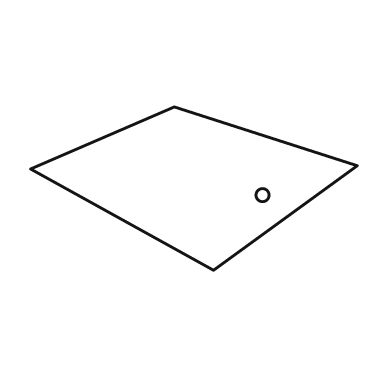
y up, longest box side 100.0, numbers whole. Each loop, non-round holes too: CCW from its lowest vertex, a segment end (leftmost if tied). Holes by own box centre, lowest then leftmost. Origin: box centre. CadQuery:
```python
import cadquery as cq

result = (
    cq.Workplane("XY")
    .moveTo(6.0, -25.0)
    .lineTo(50.0, 7.0)
    .lineTo(-6.0, 25.0)
    .lineTo(-50.0, 6.0)
    .close()
    .moveTo(21.0, -2.0)
    .circle(2.0)
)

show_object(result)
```